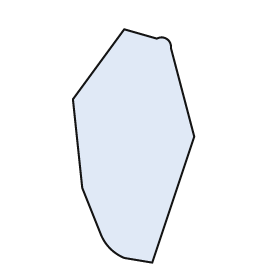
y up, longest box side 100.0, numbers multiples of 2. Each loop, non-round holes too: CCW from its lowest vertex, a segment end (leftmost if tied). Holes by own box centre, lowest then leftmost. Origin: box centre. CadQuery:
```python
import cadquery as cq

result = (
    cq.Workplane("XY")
    .moveTo(8.0, -50.0)
    .lineTo(26.0, 4.0)
    .lineTo(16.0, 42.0)
    .threePointArc((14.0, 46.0), (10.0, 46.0))
    .lineTo(-4.0, 50.0)
    .lineTo(-26.0, 20.0)
    .lineTo(-22.0, -18.0)
    .lineTo(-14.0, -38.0)
    .threePointArc((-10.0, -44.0), (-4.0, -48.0))
    .close()
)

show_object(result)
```